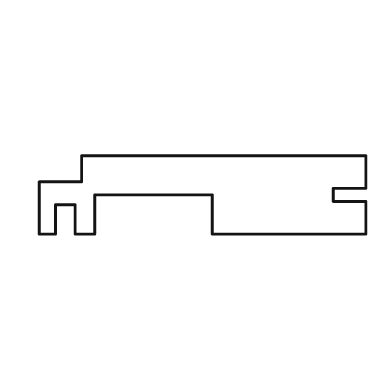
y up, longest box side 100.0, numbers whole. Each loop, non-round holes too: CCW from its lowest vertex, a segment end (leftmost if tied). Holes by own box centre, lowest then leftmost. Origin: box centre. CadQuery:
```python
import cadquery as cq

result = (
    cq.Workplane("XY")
    .moveTo(-50.0, -12.0)
    .lineTo(-45.0, -12.0)
    .lineTo(-45.0, -3.0)
    .lineTo(-39.0, -3.0)
    .lineTo(-39.0, -12.0)
    .lineTo(-33.0, -12.0)
    .lineTo(-33.0, 0.0)
    .lineTo(3.0, 0.0)
    .lineTo(3.0, -12.0)
    .lineTo(50.0, -12.0)
    .lineTo(50.0, -2.0)
    .lineTo(40.0, -2.0)
    .lineTo(40.0, 2.0)
    .lineTo(50.0, 2.0)
    .lineTo(50.0, 12.0)
    .lineTo(-37.0, 12.0)
    .lineTo(-37.0, 4.0)
    .lineTo(-50.0, 4.0)
    .close()
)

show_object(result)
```